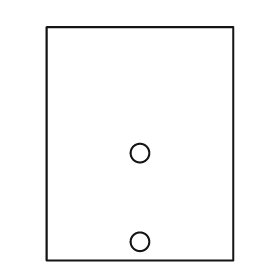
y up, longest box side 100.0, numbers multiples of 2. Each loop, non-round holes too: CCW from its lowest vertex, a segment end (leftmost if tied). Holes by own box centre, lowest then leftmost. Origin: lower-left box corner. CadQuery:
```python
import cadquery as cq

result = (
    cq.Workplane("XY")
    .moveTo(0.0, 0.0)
    .lineTo(80.0, 0.0)
    .lineTo(80.0, 100.0)
    .lineTo(0.0, 100.0)
    .close()
    .moveTo(40.0, 8.0)
    .circle(4.0)
    .moveTo(40.0, 46.0)
    .circle(4.0)
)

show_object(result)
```